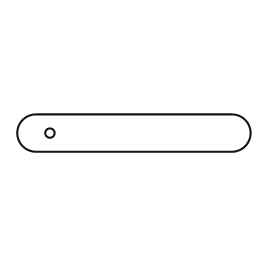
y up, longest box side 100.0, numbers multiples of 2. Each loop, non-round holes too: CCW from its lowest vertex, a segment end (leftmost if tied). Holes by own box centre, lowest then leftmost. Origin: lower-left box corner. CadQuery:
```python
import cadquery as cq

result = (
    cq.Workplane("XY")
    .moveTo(8.0, 0.0)
    .lineTo(92.0, 0.0)
    .threePointArc((100.0, 8.0), (92.0, 16.0))
    .lineTo(8.0, 16.0)
    .threePointArc((0.0, 8.0), (8.0, 0.0))
    .close()
    .moveTo(14.0, 8.0)
    .circle(2.0)
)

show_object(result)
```